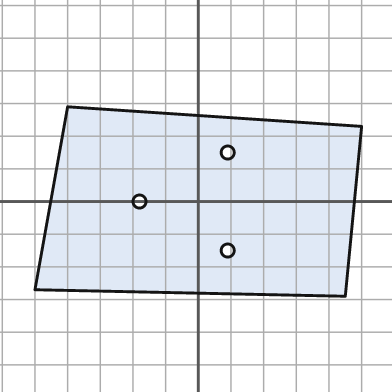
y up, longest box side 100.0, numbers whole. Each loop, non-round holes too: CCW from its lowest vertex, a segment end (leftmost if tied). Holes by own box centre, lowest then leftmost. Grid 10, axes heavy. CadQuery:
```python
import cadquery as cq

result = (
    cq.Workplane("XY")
    .moveTo(45.0, -29.0)
    .lineTo(50.0, 23.0)
    .lineTo(-40.0, 29.0)
    .lineTo(-50.0, -27.0)
    .close()
    .moveTo(9.0, -15.0)
    .circle(2.0)
    .moveTo(-18.0, 0.0)
    .circle(2.0)
    .moveTo(9.0, 15.0)
    .circle(2.0)
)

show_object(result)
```